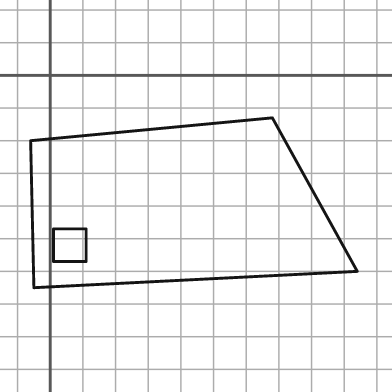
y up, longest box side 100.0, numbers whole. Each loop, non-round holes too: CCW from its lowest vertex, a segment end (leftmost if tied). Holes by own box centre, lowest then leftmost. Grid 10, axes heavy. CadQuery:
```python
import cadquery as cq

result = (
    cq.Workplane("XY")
    .moveTo(-5.0, -65.0)
    .lineTo(94.0, -60.0)
    .lineTo(68.0, -13.0)
    .lineTo(-6.0, -20.0)
    .close()
    .moveTo(1.0, -57.0)
    .lineTo(11.0, -57.0)
    .lineTo(11.0, -47.0)
    .lineTo(1.0, -47.0)
    .close()
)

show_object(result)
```